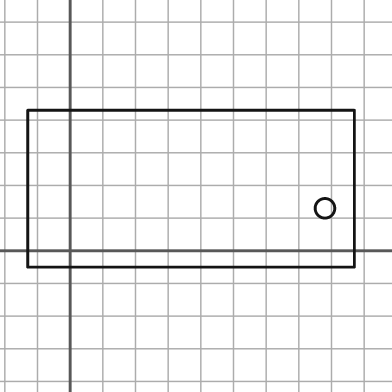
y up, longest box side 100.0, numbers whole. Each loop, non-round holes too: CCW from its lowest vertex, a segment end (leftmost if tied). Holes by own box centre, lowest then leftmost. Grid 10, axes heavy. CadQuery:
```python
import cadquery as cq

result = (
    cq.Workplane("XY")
    .moveTo(-13.0, -5.0)
    .lineTo(87.0, -5.0)
    .lineTo(87.0, 43.0)
    .lineTo(-13.0, 43.0)
    .close()
    .moveTo(78.0, 13.0)
    .circle(3.0)
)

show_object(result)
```